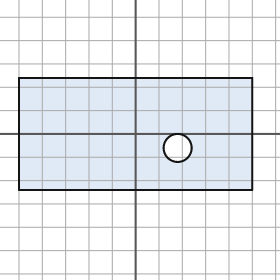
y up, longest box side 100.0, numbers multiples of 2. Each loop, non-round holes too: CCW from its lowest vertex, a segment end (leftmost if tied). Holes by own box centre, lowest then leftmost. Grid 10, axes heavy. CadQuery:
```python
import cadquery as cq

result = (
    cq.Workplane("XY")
    .moveTo(-50.0, -24.0)
    .lineTo(50.0, -24.0)
    .lineTo(50.0, 24.0)
    .lineTo(-50.0, 24.0)
    .close()
    .moveTo(18.0, -6.0)
    .circle(6.0)
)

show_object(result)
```